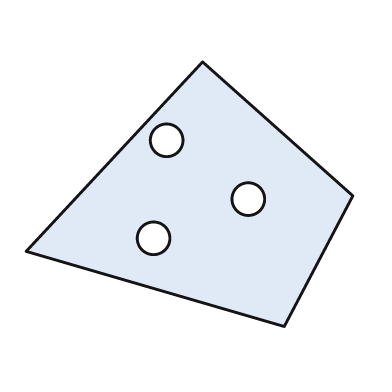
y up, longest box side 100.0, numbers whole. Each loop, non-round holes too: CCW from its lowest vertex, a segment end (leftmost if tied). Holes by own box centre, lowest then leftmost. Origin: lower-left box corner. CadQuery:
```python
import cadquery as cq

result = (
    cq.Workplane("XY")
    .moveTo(79.0, 0.0)
    .lineTo(100.0, 40.0)
    .lineTo(54.0, 81.0)
    .lineTo(0.0, 23.0)
    .close()
    .moveTo(39.0, 27.0)
    .circle(5.0)
    .moveTo(68.0, 39.0)
    .circle(5.0)
    .moveTo(43.0, 57.0)
    .circle(5.0)
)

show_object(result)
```